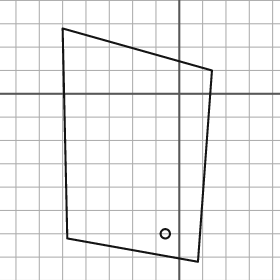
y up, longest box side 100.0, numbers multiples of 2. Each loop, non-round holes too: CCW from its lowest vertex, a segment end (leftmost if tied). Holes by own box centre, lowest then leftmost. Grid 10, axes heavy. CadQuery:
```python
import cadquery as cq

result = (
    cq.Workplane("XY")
    .moveTo(8.0, -72.0)
    .lineTo(14.0, 10.0)
    .lineTo(-50.0, 28.0)
    .lineTo(-48.0, -62.0)
    .close()
    .moveTo(-6.0, -60.0)
    .circle(2.0)
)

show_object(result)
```